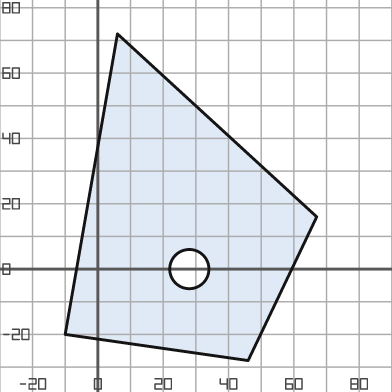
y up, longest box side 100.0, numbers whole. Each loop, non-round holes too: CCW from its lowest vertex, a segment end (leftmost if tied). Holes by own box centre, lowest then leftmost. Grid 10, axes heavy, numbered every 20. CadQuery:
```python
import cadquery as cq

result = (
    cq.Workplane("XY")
    .moveTo(46.0, -28.0)
    .lineTo(67.0, 16.0)
    .lineTo(6.0, 72.0)
    .lineTo(-10.0, -20.0)
    .close()
    .moveTo(28.0, 0.0)
    .circle(6.0)
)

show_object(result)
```